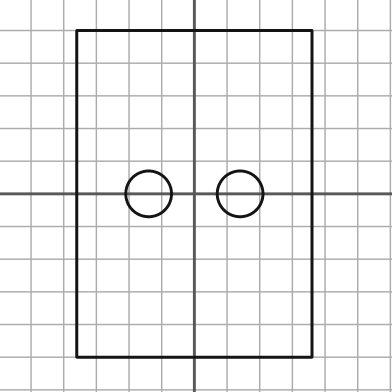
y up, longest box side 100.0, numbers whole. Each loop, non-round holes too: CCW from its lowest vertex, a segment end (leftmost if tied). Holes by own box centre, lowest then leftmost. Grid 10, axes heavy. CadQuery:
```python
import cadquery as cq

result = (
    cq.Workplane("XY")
    .moveTo(-36.0, -50.0)
    .lineTo(36.0, -50.0)
    .lineTo(36.0, 50.0)
    .lineTo(-36.0, 50.0)
    .close()
    .moveTo(-14.0, 0.0)
    .circle(7.0)
    .moveTo(14.0, 0.0)
    .circle(7.0)
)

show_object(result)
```